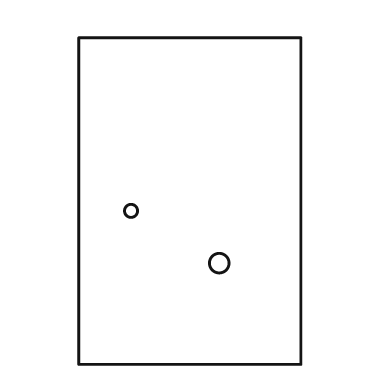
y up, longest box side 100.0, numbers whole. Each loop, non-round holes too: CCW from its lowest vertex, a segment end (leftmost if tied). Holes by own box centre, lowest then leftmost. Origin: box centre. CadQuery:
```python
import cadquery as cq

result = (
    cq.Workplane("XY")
    .moveTo(-34.0, -50.0)
    .lineTo(34.0, -50.0)
    .lineTo(34.0, 50.0)
    .lineTo(-34.0, 50.0)
    .close()
    .moveTo(9.0, -19.0)
    .circle(3.0)
    .moveTo(-18.0, -3.0)
    .circle(2.0)
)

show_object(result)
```